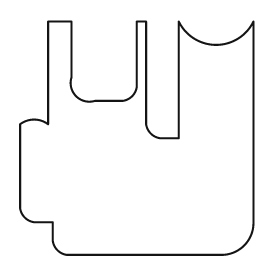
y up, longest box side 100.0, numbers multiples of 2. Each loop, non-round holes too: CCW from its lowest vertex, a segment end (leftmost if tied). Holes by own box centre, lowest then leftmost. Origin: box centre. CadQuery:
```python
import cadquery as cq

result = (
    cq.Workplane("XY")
    .moveTo(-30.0, -50.0)
    .lineTo(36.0, -50.0)
    .threePointArc((46.0, -46.0), (50.0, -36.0))
    .lineTo(50.0, 50.0)
    .threePointArc((34.0, 40.0), (18.0, 50.0))
    .lineTo(18.0, 0.0)
    .lineTo(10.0, 0.0)
    .threePointArc((6.0, 2.0), (4.0, 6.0))
    .lineTo(4.0, 50.0)
    .lineTo(0.0, 50.0)
    .lineTo(0.0, 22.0)
    .threePointArc((-2.0, 18.0), (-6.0, 16.0))
    .lineTo(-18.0, 16.0)
    .threePointArc((-26.0, 18.0), (-28.0, 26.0))
    .lineTo(-28.0, 50.0)
    .lineTo(-38.0, 50.0)
    .lineTo(-38.0, 6.0)
    .threePointArc((-44.0, 8.0), (-50.0, 6.0))
    .lineTo(-50.0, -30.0)
    .threePointArc((-48.0, -34.0), (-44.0, -36.0))
    .lineTo(-36.0, -36.0)
    .lineTo(-36.0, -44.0)
    .threePointArc((-34.0, -48.0), (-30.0, -50.0))
    .close()
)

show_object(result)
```